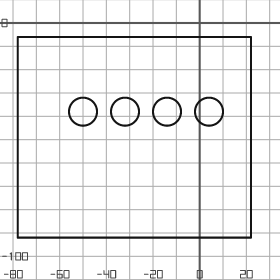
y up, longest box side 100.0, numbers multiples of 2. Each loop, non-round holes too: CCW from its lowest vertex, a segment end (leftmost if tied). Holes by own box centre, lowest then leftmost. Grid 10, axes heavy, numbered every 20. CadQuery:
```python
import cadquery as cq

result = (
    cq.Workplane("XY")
    .moveTo(-78.0, -92.0)
    .lineTo(22.0, -92.0)
    .lineTo(22.0, -6.0)
    .lineTo(-78.0, -6.0)
    .close()
    .moveTo(-50.0, -38.0)
    .circle(6.0)
    .moveTo(-32.0, -38.0)
    .circle(6.0)
    .moveTo(-14.0, -38.0)
    .circle(6.0)
    .moveTo(4.0, -38.0)
    .circle(6.0)
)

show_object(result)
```